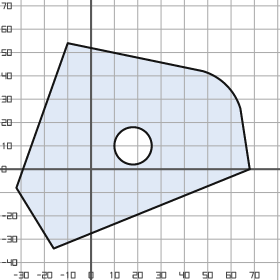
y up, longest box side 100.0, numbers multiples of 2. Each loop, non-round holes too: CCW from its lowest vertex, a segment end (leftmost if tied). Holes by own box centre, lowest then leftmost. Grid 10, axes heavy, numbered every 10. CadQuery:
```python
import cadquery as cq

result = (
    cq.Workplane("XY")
    .moveTo(-16.0, -34.0)
    .lineTo(68.0, 0.0)
    .lineTo(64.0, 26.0)
    .threePointArc((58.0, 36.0), (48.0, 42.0))
    .lineTo(-10.0, 54.0)
    .lineTo(-32.0, -8.0)
    .close()
    .moveTo(18.0, 10.0)
    .circle(8.0)
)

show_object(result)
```